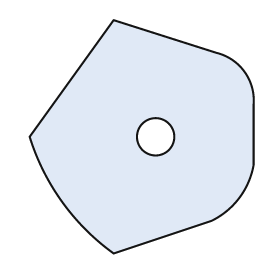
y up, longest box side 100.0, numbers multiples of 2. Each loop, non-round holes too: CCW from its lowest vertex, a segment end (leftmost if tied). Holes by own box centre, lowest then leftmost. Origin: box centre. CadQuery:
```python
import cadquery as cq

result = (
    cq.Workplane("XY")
    .moveTo(-12.0, -50.0)
    .lineTo(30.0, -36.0)
    .threePointArc((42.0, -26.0), (48.0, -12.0))
    .lineTo(48.0, 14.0)
    .threePointArc((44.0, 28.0), (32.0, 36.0))
    .lineTo(-12.0, 50.0)
    .lineTo(-48.0, 0.0)
    .threePointArc((-34.0, -28.0), (-12.0, -50.0))
    .close()
    .moveTo(6.0, 0.0)
    .circle(8.0)
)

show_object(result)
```